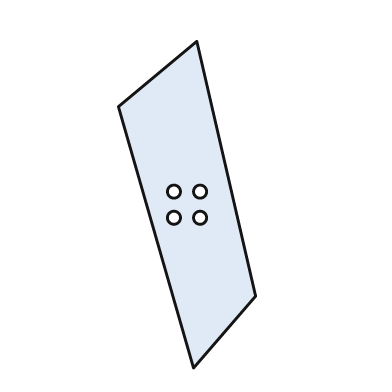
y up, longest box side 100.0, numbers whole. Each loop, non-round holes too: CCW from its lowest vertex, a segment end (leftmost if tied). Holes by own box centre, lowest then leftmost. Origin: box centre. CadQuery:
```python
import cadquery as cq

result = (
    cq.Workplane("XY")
    .moveTo(2.0, -50.0)
    .lineTo(21.0, -28.0)
    .lineTo(3.0, 50.0)
    .lineTo(-21.0, 30.0)
    .close()
    .moveTo(-4.0, -4.0)
    .circle(2.0)
    .moveTo(4.0, -4.0)
    .circle(2.0)
    .moveTo(-4.0, 4.0)
    .circle(2.0)
    .moveTo(4.0, 4.0)
    .circle(2.0)
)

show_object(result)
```